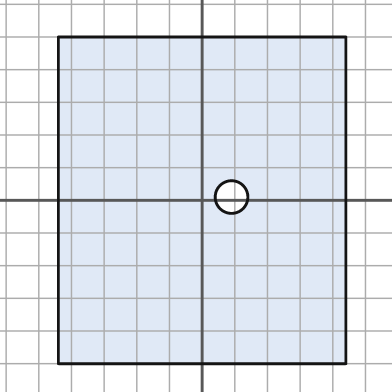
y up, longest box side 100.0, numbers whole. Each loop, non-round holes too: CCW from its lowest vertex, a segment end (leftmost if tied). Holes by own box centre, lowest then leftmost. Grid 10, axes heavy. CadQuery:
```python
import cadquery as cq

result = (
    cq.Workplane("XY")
    .moveTo(-44.0, -50.0)
    .lineTo(44.0, -50.0)
    .lineTo(44.0, 50.0)
    .lineTo(-44.0, 50.0)
    .close()
    .moveTo(9.0, 1.0)
    .circle(5.0)
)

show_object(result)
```